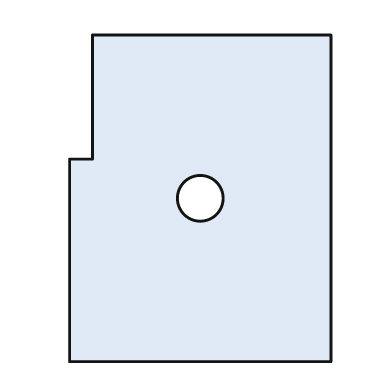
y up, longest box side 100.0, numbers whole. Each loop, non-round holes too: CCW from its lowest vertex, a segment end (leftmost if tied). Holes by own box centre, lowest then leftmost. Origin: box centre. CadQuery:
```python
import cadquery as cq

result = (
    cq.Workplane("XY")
    .moveTo(-40.0, -50.0)
    .lineTo(40.0, -50.0)
    .lineTo(40.0, 50.0)
    .lineTo(-33.0, 50.0)
    .lineTo(-33.0, 12.0)
    .lineTo(-40.0, 12.0)
    .close()
    .moveTo(0.0, 0.0)
    .circle(7.0)
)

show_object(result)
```